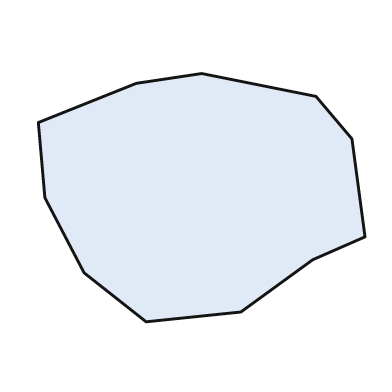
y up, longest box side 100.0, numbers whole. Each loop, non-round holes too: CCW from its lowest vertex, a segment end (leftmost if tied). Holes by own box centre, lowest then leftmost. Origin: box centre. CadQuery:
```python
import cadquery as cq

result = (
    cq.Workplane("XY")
    .moveTo(-17.0, -38.0)
    .lineTo(12.0, -35.0)
    .lineTo(34.0, -19.0)
    .lineTo(50.0, -12.0)
    .lineTo(46.0, 18.0)
    .lineTo(35.0, 31.0)
    .lineTo(0.0, 38.0)
    .lineTo(-20.0, 35.0)
    .lineTo(-50.0, 23.0)
    .lineTo(-48.0, 0.0)
    .lineTo(-36.0, -23.0)
    .close()
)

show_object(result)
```